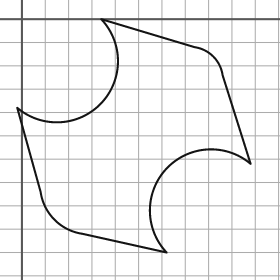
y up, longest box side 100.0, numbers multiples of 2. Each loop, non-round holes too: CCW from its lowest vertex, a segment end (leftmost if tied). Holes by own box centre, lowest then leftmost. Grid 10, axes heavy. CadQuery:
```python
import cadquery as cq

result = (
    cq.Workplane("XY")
    .moveTo(62.0, -100.0)
    .threePointArc((62.0, -64.0), (98.0, -62.0))
    .lineTo(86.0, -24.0)
    .threePointArc((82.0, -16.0), (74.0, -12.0))
    .lineTo(34.0, 0.0)
    .threePointArc((34.0, -36.0), (-2.0, -38.0))
    .lineTo(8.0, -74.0)
    .threePointArc((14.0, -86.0), (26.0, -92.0))
    .close()
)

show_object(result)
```